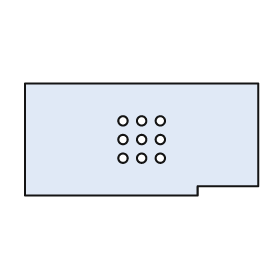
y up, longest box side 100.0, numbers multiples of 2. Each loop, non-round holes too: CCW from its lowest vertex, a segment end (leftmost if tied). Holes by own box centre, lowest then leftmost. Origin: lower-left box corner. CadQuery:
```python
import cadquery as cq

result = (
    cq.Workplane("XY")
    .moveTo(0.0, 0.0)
    .lineTo(74.0, 0.0)
    .lineTo(74.0, 4.0)
    .lineTo(100.0, 4.0)
    .lineTo(100.0, 48.0)
    .lineTo(0.0, 48.0)
    .close()
    .moveTo(42.0, 16.0)
    .circle(2.0)
    .moveTo(50.0, 16.0)
    .circle(2.0)
    .moveTo(58.0, 16.0)
    .circle(2.0)
    .moveTo(42.0, 24.0)
    .circle(2.0)
    .moveTo(50.0, 24.0)
    .circle(2.0)
    .moveTo(58.0, 24.0)
    .circle(2.0)
    .moveTo(42.0, 32.0)
    .circle(2.0)
    .moveTo(50.0, 32.0)
    .circle(2.0)
    .moveTo(58.0, 32.0)
    .circle(2.0)
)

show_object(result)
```